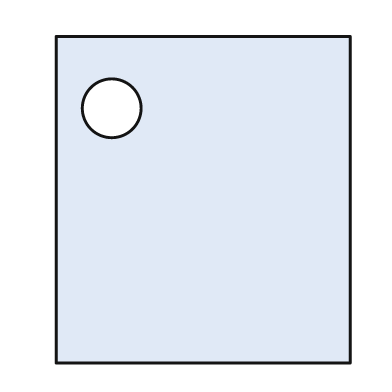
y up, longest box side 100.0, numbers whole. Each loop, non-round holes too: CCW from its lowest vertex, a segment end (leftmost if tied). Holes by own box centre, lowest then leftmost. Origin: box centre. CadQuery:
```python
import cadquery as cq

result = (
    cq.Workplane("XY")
    .moveTo(-45.0, -50.0)
    .lineTo(45.0, -50.0)
    .lineTo(45.0, 50.0)
    .lineTo(-45.0, 50.0)
    .close()
    .moveTo(-28.0, 28.0)
    .circle(9.0)
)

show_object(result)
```